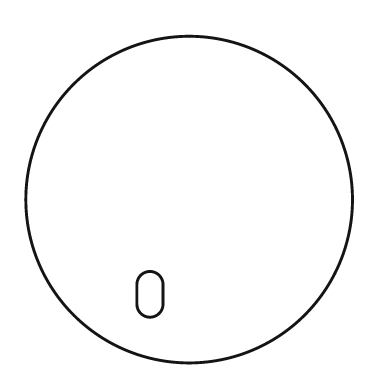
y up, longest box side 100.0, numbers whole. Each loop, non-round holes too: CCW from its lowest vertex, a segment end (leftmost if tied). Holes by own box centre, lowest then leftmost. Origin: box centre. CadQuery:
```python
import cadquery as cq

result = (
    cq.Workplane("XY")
    .moveTo(0.0, 0.0)
    .circle(50.0)
    .moveTo(-16.0, -32.0)
    .threePointArc((-12.0, -36.0), (-8.0, -32.0))
    .lineTo(-8.0, -26.0)
    .threePointArc((-12.0, -22.0), (-16.0, -26.0))
    .close()
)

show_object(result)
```